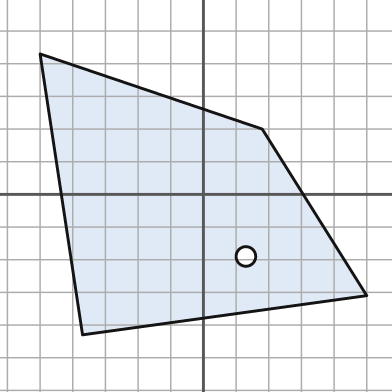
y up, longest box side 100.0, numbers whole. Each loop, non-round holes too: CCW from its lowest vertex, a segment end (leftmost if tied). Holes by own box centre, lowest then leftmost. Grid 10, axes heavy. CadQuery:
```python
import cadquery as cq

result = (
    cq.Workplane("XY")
    .moveTo(-37.0, -43.0)
    .lineTo(50.0, -31.0)
    .lineTo(18.0, 20.0)
    .lineTo(-50.0, 43.0)
    .close()
    .moveTo(13.0, -19.0)
    .circle(3.0)
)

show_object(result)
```